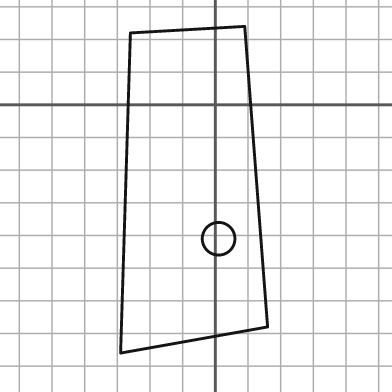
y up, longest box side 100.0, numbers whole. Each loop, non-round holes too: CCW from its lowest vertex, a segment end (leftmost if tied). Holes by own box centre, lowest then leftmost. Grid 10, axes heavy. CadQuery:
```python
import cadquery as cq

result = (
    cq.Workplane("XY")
    .moveTo(-29.0, -76.0)
    .lineTo(16.0, -68.0)
    .lineTo(9.0, 24.0)
    .lineTo(-26.0, 22.0)
    .close()
    .moveTo(1.0, -41.0)
    .circle(5.0)
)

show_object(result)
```